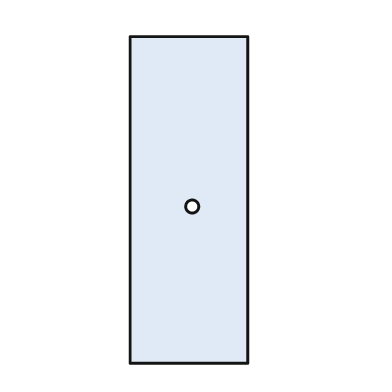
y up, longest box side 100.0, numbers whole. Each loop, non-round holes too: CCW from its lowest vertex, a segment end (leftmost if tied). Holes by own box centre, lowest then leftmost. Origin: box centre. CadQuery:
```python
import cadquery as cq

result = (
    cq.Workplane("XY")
    .moveTo(-18.0, -50.0)
    .lineTo(18.0, -50.0)
    .lineTo(18.0, 50.0)
    .lineTo(-18.0, 50.0)
    .close()
    .moveTo(1.0, -2.0)
    .circle(2.0)
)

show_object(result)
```